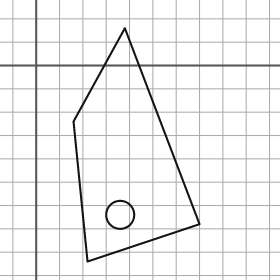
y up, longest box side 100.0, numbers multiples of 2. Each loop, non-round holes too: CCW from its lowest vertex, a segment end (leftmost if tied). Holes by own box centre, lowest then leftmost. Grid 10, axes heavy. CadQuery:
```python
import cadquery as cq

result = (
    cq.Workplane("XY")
    .moveTo(22.0, -84.0)
    .lineTo(70.0, -68.0)
    .lineTo(38.0, 16.0)
    .lineTo(16.0, -24.0)
    .close()
    .moveTo(36.0, -64.0)
    .circle(6.0)
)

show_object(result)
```